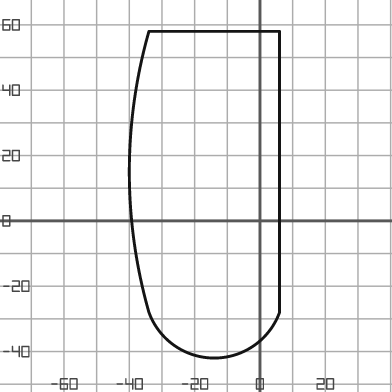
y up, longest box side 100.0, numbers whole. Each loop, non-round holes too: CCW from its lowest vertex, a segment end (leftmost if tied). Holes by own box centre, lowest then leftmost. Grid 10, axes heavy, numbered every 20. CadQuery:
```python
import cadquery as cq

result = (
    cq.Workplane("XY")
    .moveTo(-34.0, -28.0)
    .threePointArc((-14.0, -42.0), (6.0, -28.0))
    .lineTo(6.0, 58.0)
    .lineTo(-34.0, 58.0)
    .threePointArc((-40.0, 15.0), (-34.0, -28.0))
    .close()
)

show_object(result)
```